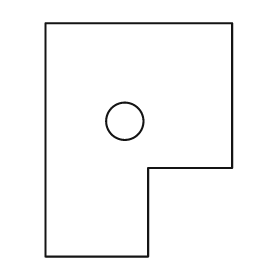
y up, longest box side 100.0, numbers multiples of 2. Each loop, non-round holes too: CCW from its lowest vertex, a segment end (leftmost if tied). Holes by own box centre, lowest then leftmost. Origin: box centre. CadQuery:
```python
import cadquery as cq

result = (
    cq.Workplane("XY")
    .moveTo(-40.0, -50.0)
    .lineTo(4.0, -50.0)
    .lineTo(4.0, -12.0)
    .lineTo(40.0, -12.0)
    .lineTo(40.0, 50.0)
    .lineTo(-40.0, 50.0)
    .close()
    .moveTo(-6.0, 8.0)
    .circle(8.0)
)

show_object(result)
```